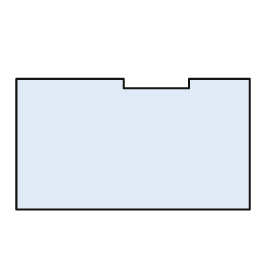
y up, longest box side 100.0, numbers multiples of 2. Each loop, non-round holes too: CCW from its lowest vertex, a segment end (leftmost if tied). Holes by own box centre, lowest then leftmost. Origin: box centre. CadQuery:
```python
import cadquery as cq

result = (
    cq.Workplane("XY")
    .moveTo(-50.0, -28.0)
    .lineTo(50.0, -28.0)
    .lineTo(50.0, 28.0)
    .lineTo(24.0, 28.0)
    .lineTo(24.0, 24.0)
    .lineTo(-4.0, 24.0)
    .lineTo(-4.0, 28.0)
    .lineTo(-50.0, 28.0)
    .close()
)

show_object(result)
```